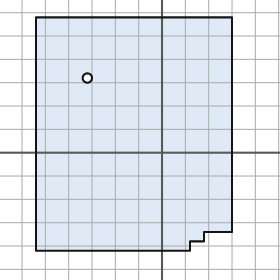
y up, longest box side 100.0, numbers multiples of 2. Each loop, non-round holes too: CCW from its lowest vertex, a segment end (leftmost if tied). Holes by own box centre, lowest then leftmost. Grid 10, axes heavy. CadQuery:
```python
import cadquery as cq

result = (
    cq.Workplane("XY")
    .moveTo(-54.0, -42.0)
    .lineTo(12.0, -42.0)
    .lineTo(12.0, -38.0)
    .lineTo(18.0, -38.0)
    .lineTo(18.0, -34.0)
    .lineTo(30.0, -34.0)
    .lineTo(30.0, 58.0)
    .lineTo(-54.0, 58.0)
    .close()
    .moveTo(-32.0, 32.0)
    .circle(2.0)
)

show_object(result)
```